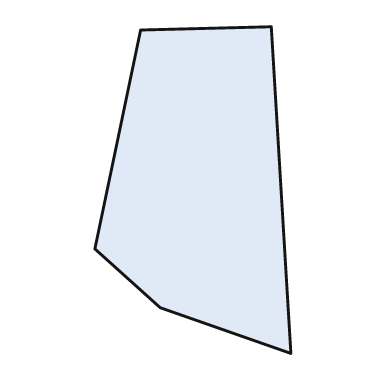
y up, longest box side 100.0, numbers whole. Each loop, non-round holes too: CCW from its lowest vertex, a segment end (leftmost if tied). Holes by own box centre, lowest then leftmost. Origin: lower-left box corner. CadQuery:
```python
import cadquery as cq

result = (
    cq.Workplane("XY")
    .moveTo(60.0, 0.0)
    .lineTo(54.0, 100.0)
    .lineTo(14.0, 99.0)
    .lineTo(0.0, 32.0)
    .lineTo(20.0, 14.0)
    .close()
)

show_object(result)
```